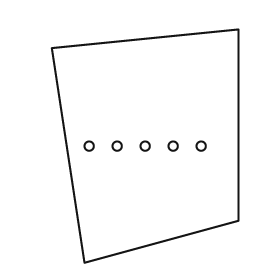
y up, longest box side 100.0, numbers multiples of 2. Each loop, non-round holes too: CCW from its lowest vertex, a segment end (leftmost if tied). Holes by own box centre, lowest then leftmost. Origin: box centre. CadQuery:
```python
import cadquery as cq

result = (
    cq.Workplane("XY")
    .moveTo(-26.0, -50.0)
    .lineTo(40.0, -32.0)
    .lineTo(40.0, 50.0)
    .lineTo(-40.0, 42.0)
    .close()
    .moveTo(-24.0, 0.0)
    .circle(2.0)
    .moveTo(-12.0, 0.0)
    .circle(2.0)
    .moveTo(0.0, 0.0)
    .circle(2.0)
    .moveTo(12.0, 0.0)
    .circle(2.0)
    .moveTo(24.0, 0.0)
    .circle(2.0)
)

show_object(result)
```